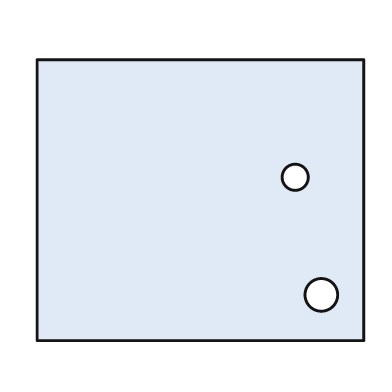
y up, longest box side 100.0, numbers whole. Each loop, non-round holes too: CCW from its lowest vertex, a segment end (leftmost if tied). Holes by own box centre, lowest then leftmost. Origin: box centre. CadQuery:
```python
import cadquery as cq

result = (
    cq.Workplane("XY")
    .moveTo(-50.0, -43.0)
    .lineTo(50.0, -43.0)
    .lineTo(50.0, 43.0)
    .lineTo(-50.0, 43.0)
    .close()
    .moveTo(37.0, -29.0)
    .circle(5.0)
    .moveTo(29.0, 7.0)
    .circle(4.0)
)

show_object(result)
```